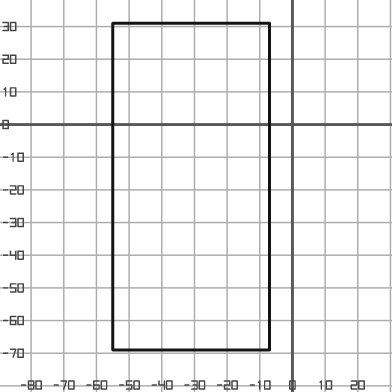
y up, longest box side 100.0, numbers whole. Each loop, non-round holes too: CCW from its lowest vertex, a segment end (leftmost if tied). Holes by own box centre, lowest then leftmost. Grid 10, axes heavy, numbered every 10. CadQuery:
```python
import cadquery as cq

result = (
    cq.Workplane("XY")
    .moveTo(-55.0, -69.0)
    .lineTo(-7.0, -69.0)
    .lineTo(-7.0, 31.0)
    .lineTo(-55.0, 31.0)
    .close()
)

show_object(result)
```